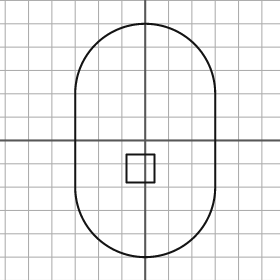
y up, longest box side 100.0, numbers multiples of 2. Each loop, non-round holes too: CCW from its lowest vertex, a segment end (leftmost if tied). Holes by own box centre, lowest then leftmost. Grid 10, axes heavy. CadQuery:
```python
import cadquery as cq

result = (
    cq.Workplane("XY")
    .moveTo(-30.0, -20.0)
    .threePointArc((0.0, -50.0), (30.0, -20.0))
    .lineTo(30.0, 20.0)
    .threePointArc((0.0, 50.0), (-30.0, 20.0))
    .close()
    .moveTo(-8.0, -18.0)
    .lineTo(4.0, -18.0)
    .lineTo(4.0, -6.0)
    .lineTo(-8.0, -6.0)
    .close()
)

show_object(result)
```